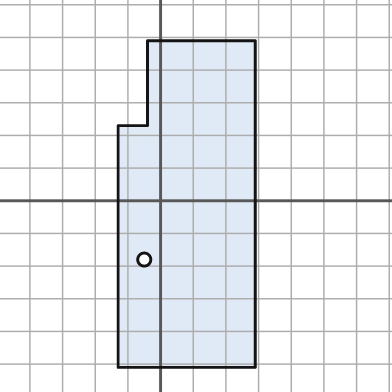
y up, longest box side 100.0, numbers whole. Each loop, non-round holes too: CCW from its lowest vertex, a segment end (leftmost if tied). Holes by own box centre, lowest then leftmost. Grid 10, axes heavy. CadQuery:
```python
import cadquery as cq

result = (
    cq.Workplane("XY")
    .moveTo(-13.0, -51.0)
    .lineTo(29.0, -51.0)
    .lineTo(29.0, 49.0)
    .lineTo(-4.0, 49.0)
    .lineTo(-4.0, 23.0)
    .lineTo(-13.0, 23.0)
    .close()
    .moveTo(-5.0, -18.0)
    .circle(2.0)
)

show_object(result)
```